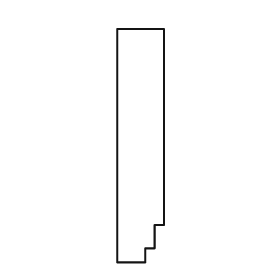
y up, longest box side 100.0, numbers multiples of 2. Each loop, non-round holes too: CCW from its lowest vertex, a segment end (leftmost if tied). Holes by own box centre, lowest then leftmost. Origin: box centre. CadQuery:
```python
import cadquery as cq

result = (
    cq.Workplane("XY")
    .moveTo(-10.0, -50.0)
    .lineTo(2.0, -50.0)
    .lineTo(2.0, -44.0)
    .lineTo(6.0, -44.0)
    .lineTo(6.0, -34.0)
    .lineTo(10.0, -34.0)
    .lineTo(10.0, 50.0)
    .lineTo(-10.0, 50.0)
    .close()
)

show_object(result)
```